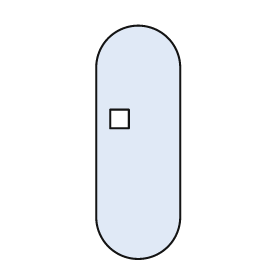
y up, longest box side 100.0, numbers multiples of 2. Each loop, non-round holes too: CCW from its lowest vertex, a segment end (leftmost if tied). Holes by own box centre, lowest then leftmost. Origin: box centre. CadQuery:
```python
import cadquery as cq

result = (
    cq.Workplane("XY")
    .moveTo(-18.0, -32.0)
    .threePointArc((0.0, -50.0), (18.0, -32.0))
    .lineTo(18.0, 32.0)
    .threePointArc((0.0, 50.0), (-18.0, 32.0))
    .close()
    .moveTo(-12.0, 6.0)
    .lineTo(-4.0, 6.0)
    .lineTo(-4.0, 14.0)
    .lineTo(-12.0, 14.0)
    .close()
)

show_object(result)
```